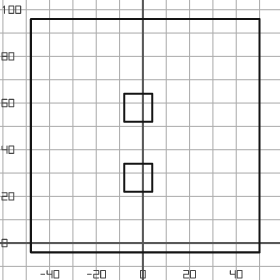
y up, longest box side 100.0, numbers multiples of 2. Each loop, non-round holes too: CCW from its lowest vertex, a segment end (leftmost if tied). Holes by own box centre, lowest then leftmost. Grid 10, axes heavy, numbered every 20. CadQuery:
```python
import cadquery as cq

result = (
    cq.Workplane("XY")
    .moveTo(-48.0, -4.0)
    .lineTo(50.0, -4.0)
    .lineTo(50.0, 96.0)
    .lineTo(-48.0, 96.0)
    .close()
    .moveTo(-8.0, 22.0)
    .lineTo(4.0, 22.0)
    .lineTo(4.0, 34.0)
    .lineTo(-8.0, 34.0)
    .close()
    .moveTo(-8.0, 52.0)
    .lineTo(4.0, 52.0)
    .lineTo(4.0, 64.0)
    .lineTo(-8.0, 64.0)
    .close()
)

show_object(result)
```